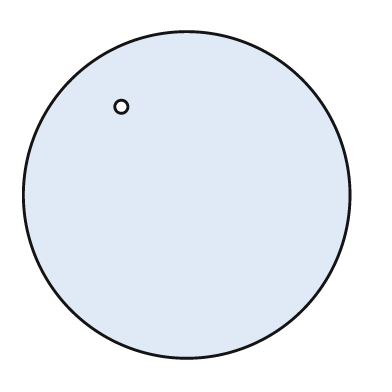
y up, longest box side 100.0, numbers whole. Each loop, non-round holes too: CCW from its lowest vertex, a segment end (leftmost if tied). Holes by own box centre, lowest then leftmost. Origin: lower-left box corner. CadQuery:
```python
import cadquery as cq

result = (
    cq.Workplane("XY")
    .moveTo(50.0, 50.0)
    .circle(50.0)
    .moveTo(30.0, 77.0)
    .circle(2.0)
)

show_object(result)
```